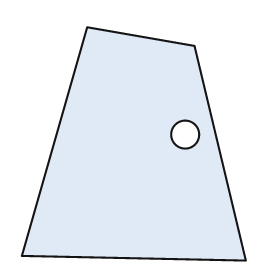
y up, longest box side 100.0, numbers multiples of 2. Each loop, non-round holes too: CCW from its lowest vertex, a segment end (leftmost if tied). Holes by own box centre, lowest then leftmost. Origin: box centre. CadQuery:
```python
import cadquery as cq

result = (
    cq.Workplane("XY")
    .moveTo(48.0, -50.0)
    .lineTo(26.0, 42.0)
    .lineTo(-20.0, 50.0)
    .lineTo(-48.0, -48.0)
    .close()
    .moveTo(22.0, 4.0)
    .circle(6.0)
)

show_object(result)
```